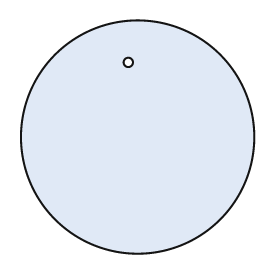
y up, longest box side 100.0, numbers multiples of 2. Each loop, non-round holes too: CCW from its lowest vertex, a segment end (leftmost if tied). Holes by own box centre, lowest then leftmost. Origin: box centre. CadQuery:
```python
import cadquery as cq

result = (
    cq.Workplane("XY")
    .moveTo(0.0, 0.0)
    .circle(50.0)
    .moveTo(-4.0, 32.0)
    .circle(2.0)
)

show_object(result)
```